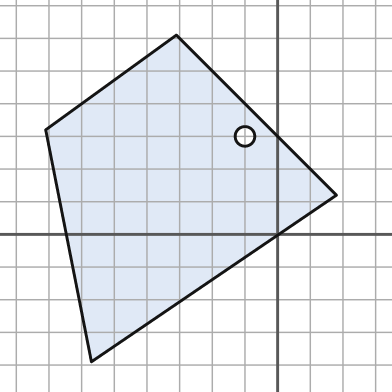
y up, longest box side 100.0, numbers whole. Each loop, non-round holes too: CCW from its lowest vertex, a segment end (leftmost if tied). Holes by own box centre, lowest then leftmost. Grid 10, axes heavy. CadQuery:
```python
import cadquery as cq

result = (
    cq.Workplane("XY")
    .moveTo(-57.0, -39.0)
    .lineTo(18.0, 12.0)
    .lineTo(-31.0, 61.0)
    .lineTo(-71.0, 32.0)
    .close()
    .moveTo(-10.0, 30.0)
    .circle(3.0)
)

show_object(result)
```